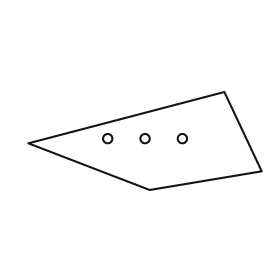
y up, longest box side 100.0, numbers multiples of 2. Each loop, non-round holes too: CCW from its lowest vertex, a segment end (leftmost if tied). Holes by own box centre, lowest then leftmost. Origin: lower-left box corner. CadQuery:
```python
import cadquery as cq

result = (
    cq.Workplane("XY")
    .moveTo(52.0, 0.0)
    .lineTo(100.0, 8.0)
    .lineTo(84.0, 42.0)
    .lineTo(0.0, 20.0)
    .close()
    .moveTo(34.0, 22.0)
    .circle(2.0)
    .moveTo(50.0, 22.0)
    .circle(2.0)
    .moveTo(66.0, 22.0)
    .circle(2.0)
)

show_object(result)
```